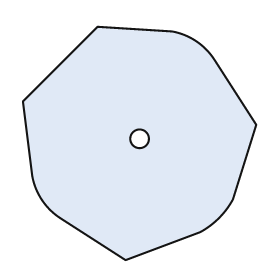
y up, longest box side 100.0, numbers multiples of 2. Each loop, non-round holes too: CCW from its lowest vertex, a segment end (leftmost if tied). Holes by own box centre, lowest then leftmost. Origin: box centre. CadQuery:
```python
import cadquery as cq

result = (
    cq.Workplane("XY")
    .moveTo(-6.0, -50.0)
    .lineTo(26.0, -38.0)
    .threePointArc((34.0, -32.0), (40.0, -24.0))
    .lineTo(50.0, 8.0)
    .lineTo(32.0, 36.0)
    .threePointArc((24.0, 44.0), (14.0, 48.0))
    .lineTo(-18.0, 50.0)
    .lineTo(-50.0, 18.0)
    .lineTo(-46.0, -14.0)
    .threePointArc((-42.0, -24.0), (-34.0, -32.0))
    .close()
    .moveTo(0.0, 2.0)
    .circle(4.0)
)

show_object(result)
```